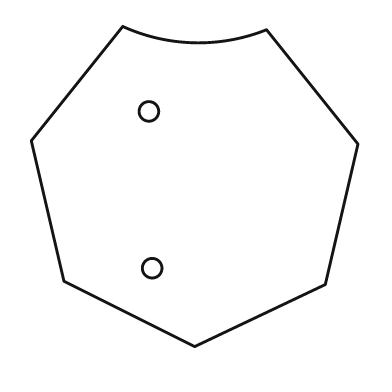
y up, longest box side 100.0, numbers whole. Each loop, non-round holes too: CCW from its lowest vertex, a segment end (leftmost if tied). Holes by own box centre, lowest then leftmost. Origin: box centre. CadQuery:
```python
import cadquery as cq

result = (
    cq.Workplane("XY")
    .moveTo(0.0, -49.0)
    .lineTo(40.0, -30.0)
    .lineTo(50.0, 13.0)
    .lineTo(22.0, 48.0)
    .threePointArc((0.0, 44.0), (-22.0, 49.0))
    .lineTo(-50.0, 14.0)
    .lineTo(-40.0, -29.0)
    .close()
    .moveTo(-13.0, -25.0)
    .circle(3.0)
    .moveTo(-14.0, 23.0)
    .circle(3.0)
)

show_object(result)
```